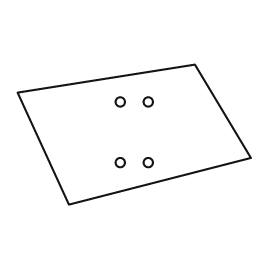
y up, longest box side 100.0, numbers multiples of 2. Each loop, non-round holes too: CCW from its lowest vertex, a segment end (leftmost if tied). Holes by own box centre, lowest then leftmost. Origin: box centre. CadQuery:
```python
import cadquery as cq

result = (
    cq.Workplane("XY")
    .moveTo(-28.0, -30.0)
    .lineTo(50.0, -10.0)
    .lineTo(26.0, 30.0)
    .lineTo(-50.0, 18.0)
    .close()
    .moveTo(-6.0, -12.0)
    .circle(2.0)
    .moveTo(6.0, -12.0)
    .circle(2.0)
    .moveTo(-6.0, 14.0)
    .circle(2.0)
    .moveTo(6.0, 14.0)
    .circle(2.0)
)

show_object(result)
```